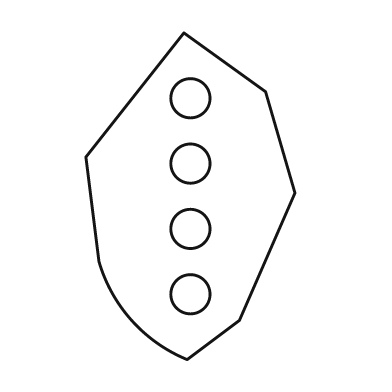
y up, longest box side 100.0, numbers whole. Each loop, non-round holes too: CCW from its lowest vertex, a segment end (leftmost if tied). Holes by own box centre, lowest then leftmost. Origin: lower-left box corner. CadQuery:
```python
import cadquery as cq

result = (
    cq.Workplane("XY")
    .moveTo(31.0, 0.0)
    .lineTo(47.0, 12.0)
    .lineTo(64.0, 51.0)
    .lineTo(55.0, 82.0)
    .lineTo(30.0, 100.0)
    .lineTo(0.0, 62.0)
    .lineTo(4.0, 30.0)
    .threePointArc((14.0, 12.0), (31.0, 0.0))
    .close()
    .moveTo(32.0, 20.0)
    .circle(6.0)
    .moveTo(32.0, 40.0)
    .circle(6.0)
    .moveTo(32.0, 60.0)
    .circle(6.0)
    .moveTo(32.0, 80.0)
    .circle(6.0)
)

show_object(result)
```